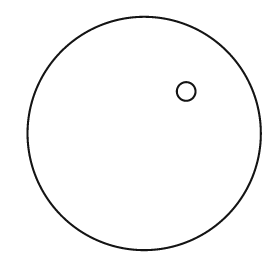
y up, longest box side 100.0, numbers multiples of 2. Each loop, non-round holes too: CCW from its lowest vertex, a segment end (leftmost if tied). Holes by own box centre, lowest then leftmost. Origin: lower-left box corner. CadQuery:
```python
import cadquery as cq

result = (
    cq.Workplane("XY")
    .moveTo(50.0, 50.0)
    .circle(50.0)
    .moveTo(68.0, 68.0)
    .circle(4.0)
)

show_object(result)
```